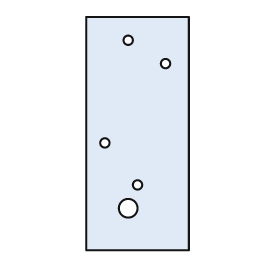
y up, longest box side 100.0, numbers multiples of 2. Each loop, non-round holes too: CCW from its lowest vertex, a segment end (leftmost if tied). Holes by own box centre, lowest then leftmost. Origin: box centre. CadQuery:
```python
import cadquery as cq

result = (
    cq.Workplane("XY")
    .moveTo(-22.0, -50.0)
    .lineTo(22.0, -50.0)
    .lineTo(22.0, 50.0)
    .lineTo(-22.0, 50.0)
    .close()
    .moveTo(-4.0, -32.0)
    .circle(4.0)
    .moveTo(0.0, -22.0)
    .circle(2.0)
    .moveTo(-14.0, -4.0)
    .circle(2.0)
    .moveTo(12.0, 30.0)
    .circle(2.0)
    .moveTo(-4.0, 40.0)
    .circle(2.0)
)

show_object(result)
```